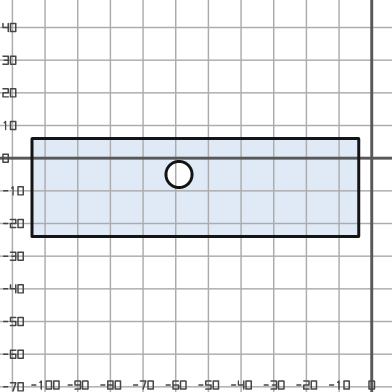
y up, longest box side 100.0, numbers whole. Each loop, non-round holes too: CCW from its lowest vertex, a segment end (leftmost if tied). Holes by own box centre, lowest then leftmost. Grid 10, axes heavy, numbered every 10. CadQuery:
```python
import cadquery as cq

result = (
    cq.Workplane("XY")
    .moveTo(-104.0, -24.0)
    .lineTo(-4.0, -24.0)
    .lineTo(-4.0, 6.0)
    .lineTo(-104.0, 6.0)
    .close()
    .moveTo(-59.0, -5.0)
    .circle(4.0)
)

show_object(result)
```